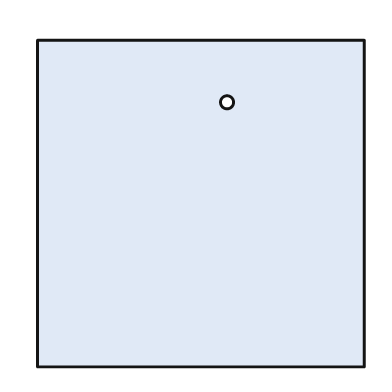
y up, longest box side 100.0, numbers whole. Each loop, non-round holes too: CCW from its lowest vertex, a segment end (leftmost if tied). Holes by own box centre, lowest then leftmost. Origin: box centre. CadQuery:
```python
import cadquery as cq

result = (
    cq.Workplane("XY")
    .moveTo(-50.0, -50.0)
    .lineTo(50.0, -50.0)
    .lineTo(50.0, 50.0)
    .lineTo(-50.0, 50.0)
    .close()
    .moveTo(8.0, 31.0)
    .circle(2.0)
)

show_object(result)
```